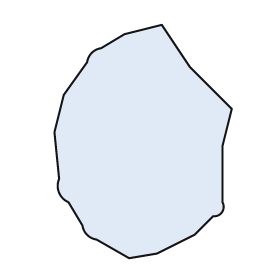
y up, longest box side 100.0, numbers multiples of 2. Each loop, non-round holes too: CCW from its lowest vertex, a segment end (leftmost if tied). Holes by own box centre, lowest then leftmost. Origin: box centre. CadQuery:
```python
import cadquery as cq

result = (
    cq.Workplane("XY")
    .moveTo(-6.0, -50.0)
    .lineTo(6.0, -48.0)
    .lineTo(22.0, -40.0)
    .lineTo(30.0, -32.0)
    .threePointArc((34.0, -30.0), (34.0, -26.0))
    .lineTo(34.0, -2.0)
    .lineTo(38.0, 14.0)
    .lineTo(20.0, 32.0)
    .lineTo(8.0, 50.0)
    .lineTo(-8.0, 46.0)
    .lineTo(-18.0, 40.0)
    .threePointArc((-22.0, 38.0), (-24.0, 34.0))
    .lineTo(-34.0, 20.0)
    .lineTo(-38.0, 4.0)
    .lineTo(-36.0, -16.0)
    .threePointArc((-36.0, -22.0), (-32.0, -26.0))
    .lineTo(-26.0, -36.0)
    .threePointArc((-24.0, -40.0), (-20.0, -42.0))
    .close()
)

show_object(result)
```